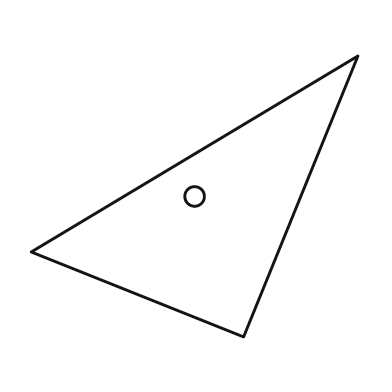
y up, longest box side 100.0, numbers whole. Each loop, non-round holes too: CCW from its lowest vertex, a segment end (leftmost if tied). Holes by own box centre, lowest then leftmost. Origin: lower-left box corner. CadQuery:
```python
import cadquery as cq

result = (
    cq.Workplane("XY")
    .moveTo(65.0, 0.0)
    .lineTo(100.0, 86.0)
    .lineTo(0.0, 26.0)
    .close()
    .moveTo(50.0, 43.0)
    .circle(3.0)
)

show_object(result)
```